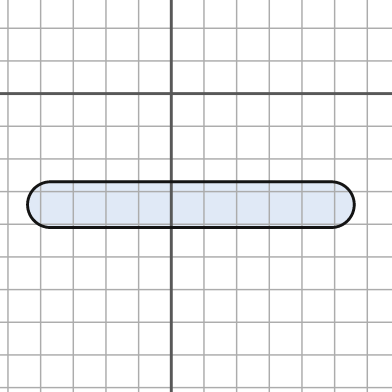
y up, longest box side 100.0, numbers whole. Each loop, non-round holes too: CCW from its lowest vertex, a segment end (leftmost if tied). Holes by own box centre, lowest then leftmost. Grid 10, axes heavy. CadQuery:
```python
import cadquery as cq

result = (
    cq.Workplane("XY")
    .moveTo(-37.0, -41.0)
    .lineTo(49.0, -41.0)
    .threePointArc((56.0, -34.0), (49.0, -27.0))
    .lineTo(-37.0, -27.0)
    .threePointArc((-44.0, -34.0), (-37.0, -41.0))
    .close()
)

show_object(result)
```